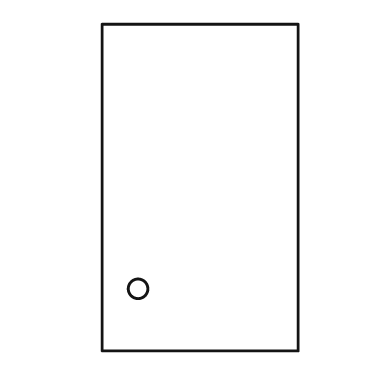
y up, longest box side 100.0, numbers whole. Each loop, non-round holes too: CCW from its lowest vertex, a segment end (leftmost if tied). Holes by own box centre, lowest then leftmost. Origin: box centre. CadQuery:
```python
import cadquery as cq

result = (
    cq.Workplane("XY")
    .moveTo(-30.0, -50.0)
    .lineTo(30.0, -50.0)
    .lineTo(30.0, 50.0)
    .lineTo(-30.0, 50.0)
    .close()
    .moveTo(-19.0, -31.0)
    .circle(3.0)
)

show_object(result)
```